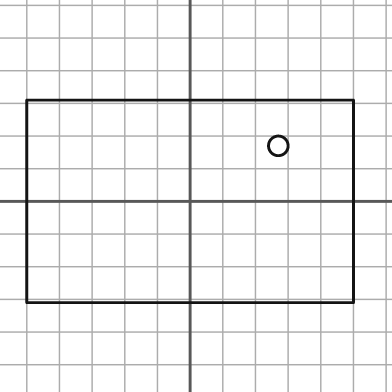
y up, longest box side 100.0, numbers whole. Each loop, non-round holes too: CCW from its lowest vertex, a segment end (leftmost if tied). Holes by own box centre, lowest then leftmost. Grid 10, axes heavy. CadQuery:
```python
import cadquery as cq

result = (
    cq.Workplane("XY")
    .moveTo(-50.0, -31.0)
    .lineTo(50.0, -31.0)
    .lineTo(50.0, 31.0)
    .lineTo(-50.0, 31.0)
    .close()
    .moveTo(27.0, 17.0)
    .circle(3.0)
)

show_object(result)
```